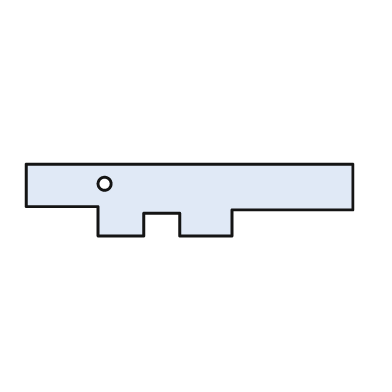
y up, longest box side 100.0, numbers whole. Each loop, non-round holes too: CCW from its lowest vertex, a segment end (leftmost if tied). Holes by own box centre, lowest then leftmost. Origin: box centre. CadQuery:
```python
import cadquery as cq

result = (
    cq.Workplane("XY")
    .moveTo(-28.0, -11.0)
    .lineTo(-14.0, -11.0)
    .lineTo(-14.0, -4.0)
    .lineTo(-3.0, -4.0)
    .lineTo(-3.0, -11.0)
    .lineTo(13.0, -11.0)
    .lineTo(13.0, -3.0)
    .lineTo(50.0, -3.0)
    .lineTo(50.0, 11.0)
    .lineTo(-50.0, 11.0)
    .lineTo(-50.0, -2.0)
    .lineTo(-28.0, -2.0)
    .close()
    .moveTo(-26.0, 5.0)
    .circle(2.0)
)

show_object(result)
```